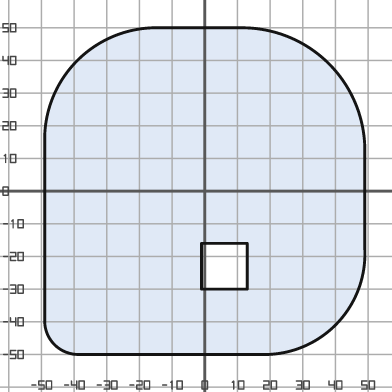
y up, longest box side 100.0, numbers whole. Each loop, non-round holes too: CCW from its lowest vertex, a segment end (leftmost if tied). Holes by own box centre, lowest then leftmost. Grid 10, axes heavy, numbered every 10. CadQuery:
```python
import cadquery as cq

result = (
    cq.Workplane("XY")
    .moveTo(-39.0, -50.0)
    .lineTo(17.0, -50.0)
    .threePointArc((40.0, -41.0), (49.0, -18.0))
    .lineTo(49.0, 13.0)
    .threePointArc((38.0, 39.0), (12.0, 50.0))
    .lineTo(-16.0, 50.0)
    .threePointArc((-39.0, 40.0), (-49.0, 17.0))
    .lineTo(-49.0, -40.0)
    .threePointArc((-46.0, -47.0), (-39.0, -50.0))
    .close()
    .moveTo(-1.0, -30.0)
    .lineTo(13.0, -30.0)
    .lineTo(13.0, -16.0)
    .lineTo(-1.0, -16.0)
    .close()
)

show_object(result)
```